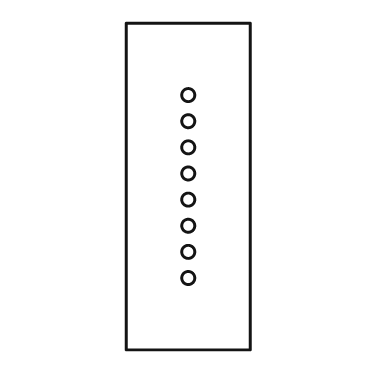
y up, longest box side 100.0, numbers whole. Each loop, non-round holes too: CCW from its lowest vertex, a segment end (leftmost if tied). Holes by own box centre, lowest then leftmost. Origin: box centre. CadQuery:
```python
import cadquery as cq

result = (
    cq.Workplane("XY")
    .moveTo(-19.0, -50.0)
    .lineTo(19.0, -50.0)
    .lineTo(19.0, 50.0)
    .lineTo(-19.0, 50.0)
    .close()
    .moveTo(0.0, -28.0)
    .circle(2.0)
    .moveTo(0.0, -20.0)
    .circle(2.0)
    .moveTo(0.0, -12.0)
    .circle(2.0)
    .moveTo(0.0, -4.0)
    .circle(2.0)
    .moveTo(0.0, 4.0)
    .circle(2.0)
    .moveTo(0.0, 12.0)
    .circle(2.0)
    .moveTo(0.0, 20.0)
    .circle(2.0)
    .moveTo(0.0, 28.0)
    .circle(2.0)
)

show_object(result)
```